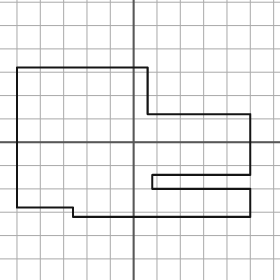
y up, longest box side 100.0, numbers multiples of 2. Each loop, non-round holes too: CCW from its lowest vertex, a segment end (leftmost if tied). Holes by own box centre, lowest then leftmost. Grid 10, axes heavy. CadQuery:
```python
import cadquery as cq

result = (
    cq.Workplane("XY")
    .moveTo(-26.0, -32.0)
    .lineTo(50.0, -32.0)
    .lineTo(50.0, -20.0)
    .lineTo(8.0, -20.0)
    .lineTo(8.0, -14.0)
    .lineTo(50.0, -14.0)
    .lineTo(50.0, 12.0)
    .lineTo(6.0, 12.0)
    .lineTo(6.0, 32.0)
    .lineTo(-50.0, 32.0)
    .lineTo(-50.0, -28.0)
    .lineTo(-26.0, -28.0)
    .close()
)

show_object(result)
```